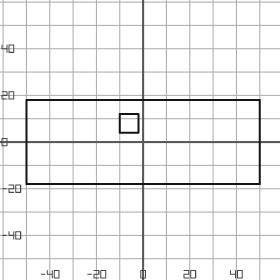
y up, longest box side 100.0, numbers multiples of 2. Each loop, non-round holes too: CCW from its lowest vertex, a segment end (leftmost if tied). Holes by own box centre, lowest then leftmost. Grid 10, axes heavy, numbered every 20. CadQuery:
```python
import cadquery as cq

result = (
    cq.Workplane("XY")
    .moveTo(-50.0, -18.0)
    .lineTo(50.0, -18.0)
    .lineTo(50.0, 18.0)
    .lineTo(-50.0, 18.0)
    .close()
    .moveTo(-10.0, 4.0)
    .lineTo(-2.0, 4.0)
    .lineTo(-2.0, 12.0)
    .lineTo(-10.0, 12.0)
    .close()
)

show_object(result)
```